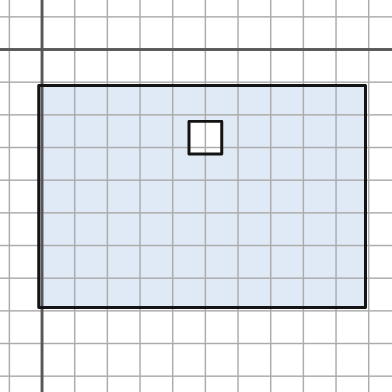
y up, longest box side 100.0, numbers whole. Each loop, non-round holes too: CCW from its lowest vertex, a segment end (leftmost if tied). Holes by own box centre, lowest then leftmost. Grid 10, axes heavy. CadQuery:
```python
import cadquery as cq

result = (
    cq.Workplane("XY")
    .moveTo(-1.0, -79.0)
    .lineTo(99.0, -79.0)
    .lineTo(99.0, -11.0)
    .lineTo(-1.0, -11.0)
    .close()
    .moveTo(45.0, -32.0)
    .lineTo(55.0, -32.0)
    .lineTo(55.0, -22.0)
    .lineTo(45.0, -22.0)
    .close()
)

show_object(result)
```